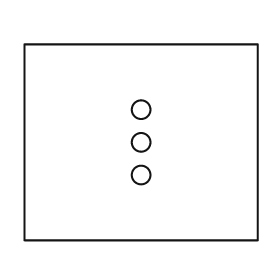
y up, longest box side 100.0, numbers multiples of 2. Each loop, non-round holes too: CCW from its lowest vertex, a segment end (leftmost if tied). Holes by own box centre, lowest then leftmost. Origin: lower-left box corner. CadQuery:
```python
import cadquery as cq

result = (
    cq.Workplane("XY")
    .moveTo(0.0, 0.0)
    .lineTo(100.0, 0.0)
    .lineTo(100.0, 84.0)
    .lineTo(0.0, 84.0)
    .close()
    .moveTo(50.0, 28.0)
    .circle(4.0)
    .moveTo(50.0, 42.0)
    .circle(4.0)
    .moveTo(50.0, 56.0)
    .circle(4.0)
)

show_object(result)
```